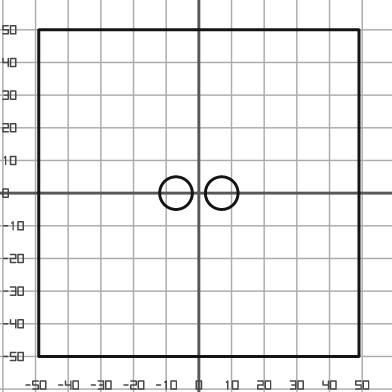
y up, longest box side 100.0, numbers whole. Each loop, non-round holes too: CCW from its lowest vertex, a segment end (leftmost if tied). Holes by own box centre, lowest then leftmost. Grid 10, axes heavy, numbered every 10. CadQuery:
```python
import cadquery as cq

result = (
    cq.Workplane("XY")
    .moveTo(-49.0, -50.0)
    .lineTo(49.0, -50.0)
    .lineTo(49.0, 50.0)
    .lineTo(-49.0, 50.0)
    .close()
    .moveTo(-7.0, 0.0)
    .circle(5.0)
    .moveTo(7.0, 0.0)
    .circle(5.0)
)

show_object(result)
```